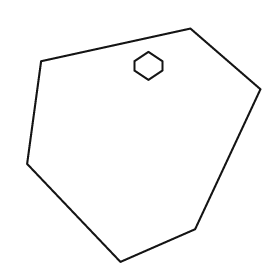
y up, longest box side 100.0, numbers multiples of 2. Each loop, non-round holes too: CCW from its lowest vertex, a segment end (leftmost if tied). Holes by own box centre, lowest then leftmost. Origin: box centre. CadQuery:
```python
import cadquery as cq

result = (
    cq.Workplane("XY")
    .moveTo(-10.0, -50.0)
    .lineTo(22.0, -36.0)
    .lineTo(50.0, 24.0)
    .lineTo(20.0, 50.0)
    .lineTo(-44.0, 36.0)
    .lineTo(-50.0, -8.0)
    .close()
    .moveTo(2.0, 28.0)
    .lineTo(8.0, 32.0)
    .lineTo(8.0, 36.0)
    .lineTo(2.0, 40.0)
    .lineTo(-4.0, 36.0)
    .lineTo(-4.0, 32.0)
    .close()
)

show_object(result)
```